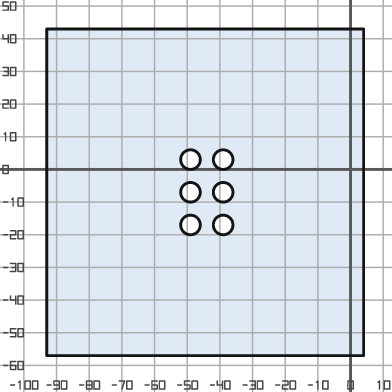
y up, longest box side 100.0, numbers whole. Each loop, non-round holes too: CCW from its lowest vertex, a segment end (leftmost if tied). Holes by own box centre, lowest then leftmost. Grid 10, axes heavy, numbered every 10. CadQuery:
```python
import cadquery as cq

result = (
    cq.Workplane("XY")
    .moveTo(-93.0, -57.0)
    .lineTo(4.0, -57.0)
    .lineTo(4.0, 43.0)
    .lineTo(-93.0, 43.0)
    .close()
    .moveTo(-49.0, -17.0)
    .circle(3.0)
    .moveTo(-39.0, -17.0)
    .circle(3.0)
    .moveTo(-49.0, -7.0)
    .circle(3.0)
    .moveTo(-39.0, -7.0)
    .circle(3.0)
    .moveTo(-49.0, 3.0)
    .circle(3.0)
    .moveTo(-39.0, 3.0)
    .circle(3.0)
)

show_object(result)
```